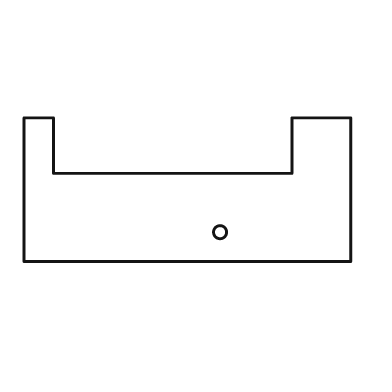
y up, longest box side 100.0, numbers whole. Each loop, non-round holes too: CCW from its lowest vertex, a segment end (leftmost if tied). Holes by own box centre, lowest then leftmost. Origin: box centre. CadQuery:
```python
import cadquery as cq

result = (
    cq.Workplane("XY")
    .moveTo(-50.0, -22.0)
    .lineTo(50.0, -22.0)
    .lineTo(50.0, 22.0)
    .lineTo(32.0, 22.0)
    .lineTo(32.0, 5.0)
    .lineTo(-41.0, 5.0)
    .lineTo(-41.0, 22.0)
    .lineTo(-50.0, 22.0)
    .close()
    .moveTo(10.0, -13.0)
    .circle(2.0)
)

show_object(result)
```